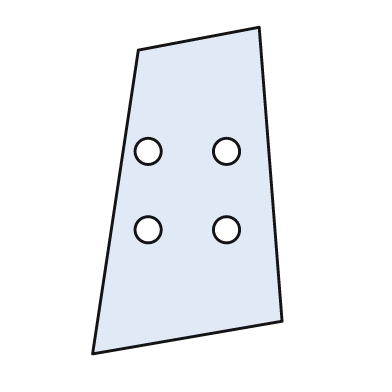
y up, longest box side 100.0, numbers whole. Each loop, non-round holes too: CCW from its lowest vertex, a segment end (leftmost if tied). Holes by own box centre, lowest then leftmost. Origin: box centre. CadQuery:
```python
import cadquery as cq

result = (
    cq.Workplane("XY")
    .moveTo(-29.0, -50.0)
    .lineTo(29.0, -40.0)
    .lineTo(22.0, 50.0)
    .lineTo(-15.0, 43.0)
    .close()
    .moveTo(-12.0, -12.0)
    .circle(4.0)
    .moveTo(12.0, -12.0)
    .circle(4.0)
    .moveTo(-12.0, 12.0)
    .circle(4.0)
    .moveTo(12.0, 12.0)
    .circle(4.0)
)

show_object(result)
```